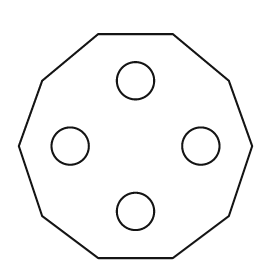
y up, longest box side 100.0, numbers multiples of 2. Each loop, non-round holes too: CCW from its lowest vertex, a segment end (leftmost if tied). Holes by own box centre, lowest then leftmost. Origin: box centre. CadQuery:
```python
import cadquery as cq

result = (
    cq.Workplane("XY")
    .moveTo(-16.0, -48.0)
    .lineTo(16.0, -48.0)
    .lineTo(40.0, -30.0)
    .lineTo(50.0, 0.0)
    .lineTo(40.0, 28.0)
    .lineTo(16.0, 48.0)
    .lineTo(-16.0, 48.0)
    .lineTo(-40.0, 28.0)
    .lineTo(-50.0, 0.0)
    .lineTo(-40.0, -30.0)
    .close()
    .moveTo(0.0, -28.0)
    .circle(8.0)
    .moveTo(-28.0, 0.0)
    .circle(8.0)
    .moveTo(28.0, 0.0)
    .circle(8.0)
    .moveTo(0.0, 28.0)
    .circle(8.0)
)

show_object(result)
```